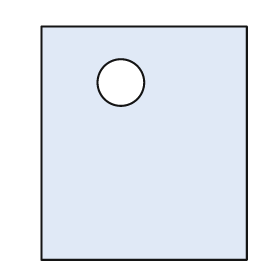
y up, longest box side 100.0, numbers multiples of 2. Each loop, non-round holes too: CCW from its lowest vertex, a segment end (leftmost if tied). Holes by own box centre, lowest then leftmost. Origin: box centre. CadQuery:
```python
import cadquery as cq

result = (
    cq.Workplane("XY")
    .moveTo(-44.0, -50.0)
    .lineTo(44.0, -50.0)
    .lineTo(44.0, 50.0)
    .lineTo(-44.0, 50.0)
    .close()
    .moveTo(-10.0, 26.0)
    .circle(10.0)
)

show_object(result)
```